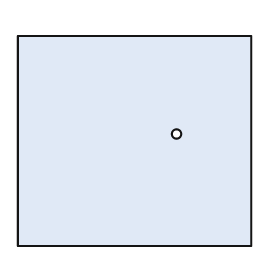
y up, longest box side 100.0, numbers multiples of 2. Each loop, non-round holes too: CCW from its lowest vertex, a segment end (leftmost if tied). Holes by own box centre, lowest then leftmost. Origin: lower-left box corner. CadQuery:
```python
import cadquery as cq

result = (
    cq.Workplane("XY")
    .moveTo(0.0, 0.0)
    .lineTo(100.0, 0.0)
    .lineTo(100.0, 90.0)
    .lineTo(0.0, 90.0)
    .close()
    .moveTo(68.0, 48.0)
    .circle(2.0)
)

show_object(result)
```